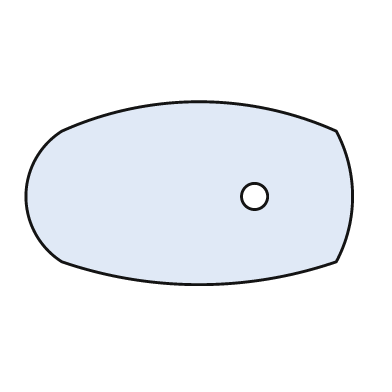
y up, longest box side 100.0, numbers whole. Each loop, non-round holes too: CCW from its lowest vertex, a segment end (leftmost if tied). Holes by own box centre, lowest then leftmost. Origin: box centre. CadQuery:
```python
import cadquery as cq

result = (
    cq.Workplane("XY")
    .moveTo(-39.0, -21.0)
    .threePointArc((3.0, -28.0), (45.0, -21.0))
    .threePointArc((50.0, -1.0), (45.0, 19.0))
    .threePointArc((3.0, 28.0), (-39.0, 19.0))
    .threePointArc((-50.0, -1.0), (-39.0, -21.0))
    .close()
    .moveTo(20.0, -1.0)
    .circle(4.0)
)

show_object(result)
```